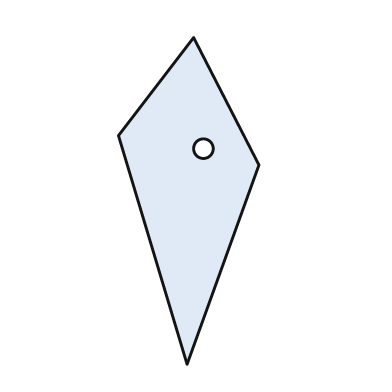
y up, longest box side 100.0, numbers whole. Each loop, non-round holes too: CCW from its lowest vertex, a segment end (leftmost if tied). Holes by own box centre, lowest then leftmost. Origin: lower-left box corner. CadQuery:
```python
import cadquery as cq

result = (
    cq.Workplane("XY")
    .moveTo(21.0, 0.0)
    .lineTo(43.0, 61.0)
    .lineTo(23.0, 100.0)
    .lineTo(0.0, 70.0)
    .close()
    .moveTo(26.0, 66.0)
    .circle(3.0)
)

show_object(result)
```